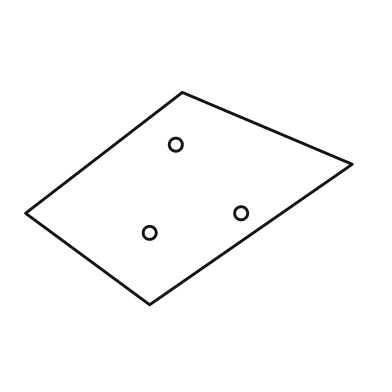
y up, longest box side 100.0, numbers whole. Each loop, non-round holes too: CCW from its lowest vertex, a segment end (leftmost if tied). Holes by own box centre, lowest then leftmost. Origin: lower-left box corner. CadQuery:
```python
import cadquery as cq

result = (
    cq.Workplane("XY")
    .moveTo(38.0, 0.0)
    .lineTo(100.0, 43.0)
    .lineTo(48.0, 65.0)
    .lineTo(0.0, 28.0)
    .close()
    .moveTo(38.0, 22.0)
    .circle(2.0)
    .moveTo(66.0, 28.0)
    .circle(2.0)
    .moveTo(46.0, 49.0)
    .circle(2.0)
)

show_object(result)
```